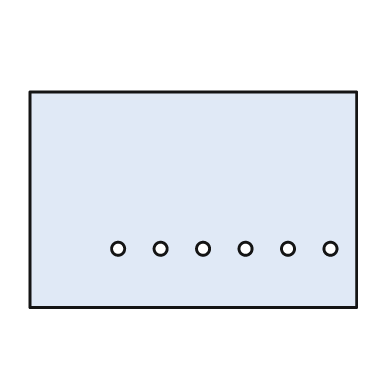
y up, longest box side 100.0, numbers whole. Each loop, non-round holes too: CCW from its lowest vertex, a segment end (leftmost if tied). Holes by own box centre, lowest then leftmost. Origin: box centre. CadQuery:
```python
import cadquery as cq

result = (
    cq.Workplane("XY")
    .moveTo(-50.0, -33.0)
    .lineTo(50.0, -33.0)
    .lineTo(50.0, 33.0)
    .lineTo(-50.0, 33.0)
    .close()
    .moveTo(-23.0, -15.0)
    .circle(2.0)
    .moveTo(-10.0, -15.0)
    .circle(2.0)
    .moveTo(3.0, -15.0)
    .circle(2.0)
    .moveTo(16.0, -15.0)
    .circle(2.0)
    .moveTo(29.0, -15.0)
    .circle(2.0)
    .moveTo(42.0, -15.0)
    .circle(2.0)
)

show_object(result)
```